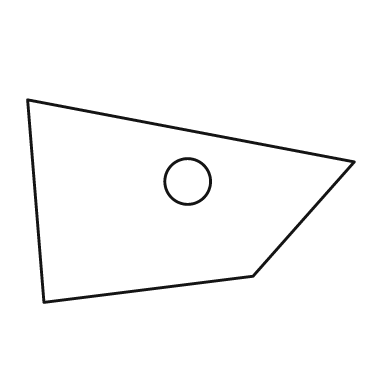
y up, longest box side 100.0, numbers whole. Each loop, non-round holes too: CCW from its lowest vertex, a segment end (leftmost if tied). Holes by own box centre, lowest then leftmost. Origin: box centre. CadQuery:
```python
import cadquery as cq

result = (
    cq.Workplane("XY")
    .moveTo(-45.0, -31.0)
    .lineTo(19.0, -23.0)
    .lineTo(50.0, 12.0)
    .lineTo(-50.0, 31.0)
    .close()
    .moveTo(-1.0, 6.0)
    .circle(7.0)
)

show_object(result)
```